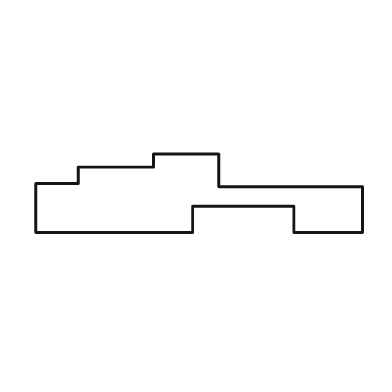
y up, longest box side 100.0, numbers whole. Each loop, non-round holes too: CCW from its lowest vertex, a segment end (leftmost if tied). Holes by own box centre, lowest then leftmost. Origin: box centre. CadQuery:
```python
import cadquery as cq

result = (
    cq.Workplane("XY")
    .moveTo(-50.0, -12.0)
    .lineTo(-2.0, -12.0)
    .lineTo(-2.0, -4.0)
    .lineTo(29.0, -4.0)
    .lineTo(29.0, -12.0)
    .lineTo(50.0, -12.0)
    .lineTo(50.0, 2.0)
    .lineTo(6.0, 2.0)
    .lineTo(6.0, 12.0)
    .lineTo(-14.0, 12.0)
    .lineTo(-14.0, 8.0)
    .lineTo(-37.0, 8.0)
    .lineTo(-37.0, 3.0)
    .lineTo(-50.0, 3.0)
    .close()
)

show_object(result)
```